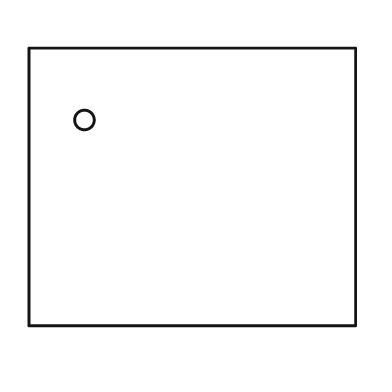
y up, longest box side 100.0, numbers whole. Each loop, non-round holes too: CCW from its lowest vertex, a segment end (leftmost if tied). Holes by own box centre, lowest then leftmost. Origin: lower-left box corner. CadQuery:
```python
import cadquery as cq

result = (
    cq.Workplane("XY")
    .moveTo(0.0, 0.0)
    .lineTo(100.0, 0.0)
    .lineTo(100.0, 85.0)
    .lineTo(0.0, 85.0)
    .close()
    .moveTo(17.0, 63.0)
    .circle(3.0)
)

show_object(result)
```